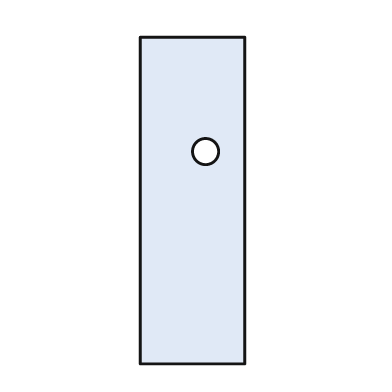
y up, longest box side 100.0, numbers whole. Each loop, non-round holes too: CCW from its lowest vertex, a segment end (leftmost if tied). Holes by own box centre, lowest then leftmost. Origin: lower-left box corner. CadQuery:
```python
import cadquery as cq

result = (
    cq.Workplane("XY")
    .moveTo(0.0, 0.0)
    .lineTo(32.0, 0.0)
    .lineTo(32.0, 100.0)
    .lineTo(0.0, 100.0)
    .close()
    .moveTo(20.0, 65.0)
    .circle(4.0)
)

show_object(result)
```